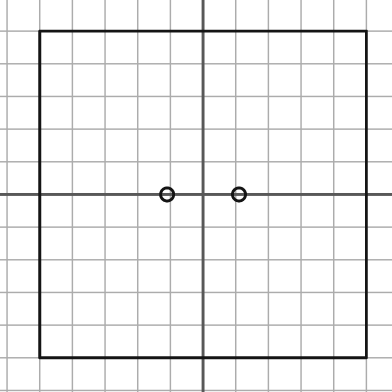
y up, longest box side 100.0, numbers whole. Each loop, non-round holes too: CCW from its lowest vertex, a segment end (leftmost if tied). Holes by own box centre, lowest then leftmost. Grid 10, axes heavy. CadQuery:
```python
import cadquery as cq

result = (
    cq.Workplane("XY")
    .moveTo(-50.0, -50.0)
    .lineTo(50.0, -50.0)
    .lineTo(50.0, 50.0)
    .lineTo(-50.0, 50.0)
    .close()
    .moveTo(-11.0, 0.0)
    .circle(2.0)
    .moveTo(11.0, 0.0)
    .circle(2.0)
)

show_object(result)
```